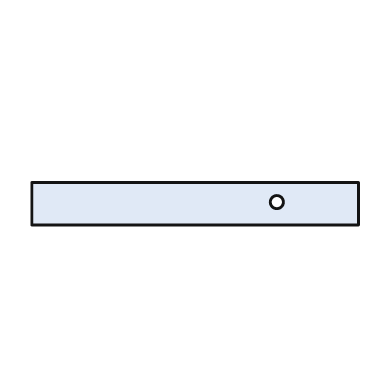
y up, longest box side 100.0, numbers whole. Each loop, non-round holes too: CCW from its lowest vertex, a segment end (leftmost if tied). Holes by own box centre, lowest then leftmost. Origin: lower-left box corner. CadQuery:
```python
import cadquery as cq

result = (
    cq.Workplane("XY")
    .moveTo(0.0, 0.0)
    .lineTo(100.0, 0.0)
    .lineTo(100.0, 13.0)
    .lineTo(0.0, 13.0)
    .close()
    .moveTo(75.0, 7.0)
    .circle(2.0)
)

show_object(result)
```